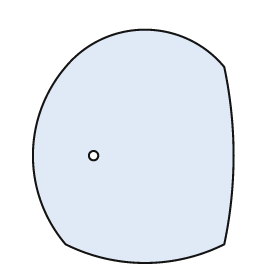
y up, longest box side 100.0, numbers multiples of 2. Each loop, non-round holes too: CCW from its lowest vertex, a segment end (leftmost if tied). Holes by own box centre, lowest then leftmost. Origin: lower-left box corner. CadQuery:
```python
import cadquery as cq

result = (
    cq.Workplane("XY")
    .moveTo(14.0, 8.0)
    .threePointArc((48.0, 0.0), (82.0, 8.0))
    .threePointArc((86.0, 46.0), (82.0, 84.0))
    .threePointArc((48.0, 100.0), (14.0, 84.0))
    .threePointArc((0.0, 46.0), (14.0, 8.0))
    .close()
    .moveTo(26.0, 46.0)
    .circle(2.0)
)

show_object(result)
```